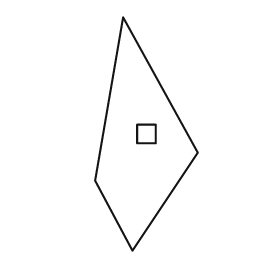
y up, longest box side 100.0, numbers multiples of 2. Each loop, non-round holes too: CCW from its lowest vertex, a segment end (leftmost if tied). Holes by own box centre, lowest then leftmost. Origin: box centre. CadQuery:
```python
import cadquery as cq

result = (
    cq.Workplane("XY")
    .moveTo(-6.0, -50.0)
    .lineTo(22.0, -8.0)
    .lineTo(-10.0, 50.0)
    .lineTo(-22.0, -20.0)
    .close()
    .moveTo(-4.0, -4.0)
    .lineTo(4.0, -4.0)
    .lineTo(4.0, 4.0)
    .lineTo(-4.0, 4.0)
    .close()
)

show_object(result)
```